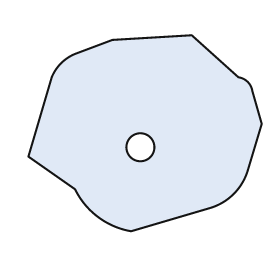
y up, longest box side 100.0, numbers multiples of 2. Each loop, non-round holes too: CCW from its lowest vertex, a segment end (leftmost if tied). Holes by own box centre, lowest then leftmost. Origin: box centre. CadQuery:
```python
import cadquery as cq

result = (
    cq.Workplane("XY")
    .moveTo(-6.0, -42.0)
    .lineTo(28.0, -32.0)
    .threePointArc((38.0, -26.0), (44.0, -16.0))
    .lineTo(50.0, 4.0)
    .lineTo(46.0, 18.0)
    .threePointArc((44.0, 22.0), (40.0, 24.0))
    .lineTo(20.0, 42.0)
    .lineTo(-14.0, 40.0)
    .lineTo(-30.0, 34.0)
    .threePointArc((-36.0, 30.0), (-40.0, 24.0))
    .lineTo(-50.0, -10.0)
    .lineTo(-30.0, -24.0)
    .threePointArc((-20.0, -36.0), (-6.0, -42.0))
    .close()
    .moveTo(-2.0, -6.0)
    .circle(6.0)
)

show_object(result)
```